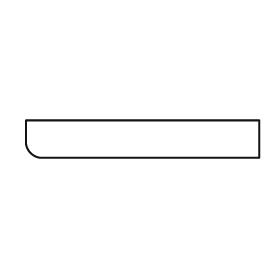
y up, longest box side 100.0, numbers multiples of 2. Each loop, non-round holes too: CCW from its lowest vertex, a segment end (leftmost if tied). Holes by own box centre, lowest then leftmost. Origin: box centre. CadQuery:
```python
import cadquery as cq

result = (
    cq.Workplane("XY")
    .moveTo(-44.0, -8.0)
    .lineTo(50.0, -8.0)
    .lineTo(50.0, 8.0)
    .lineTo(-50.0, 8.0)
    .lineTo(-50.0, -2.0)
    .threePointArc((-48.0, -6.0), (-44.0, -8.0))
    .close()
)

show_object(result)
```